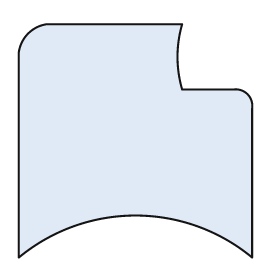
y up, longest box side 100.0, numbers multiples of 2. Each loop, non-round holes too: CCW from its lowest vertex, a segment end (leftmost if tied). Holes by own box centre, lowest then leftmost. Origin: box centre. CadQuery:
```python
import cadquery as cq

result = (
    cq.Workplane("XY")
    .moveTo(-50.0, -50.0)
    .threePointArc((0.0, -32.0), (50.0, -50.0))
    .lineTo(50.0, 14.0)
    .threePointArc((48.0, 20.0), (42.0, 22.0))
    .lineTo(20.0, 22.0)
    .threePointArc((18.0, 36.0), (20.0, 50.0))
    .lineTo(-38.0, 50.0)
    .threePointArc((-46.0, 46.0), (-50.0, 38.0))
    .close()
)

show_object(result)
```